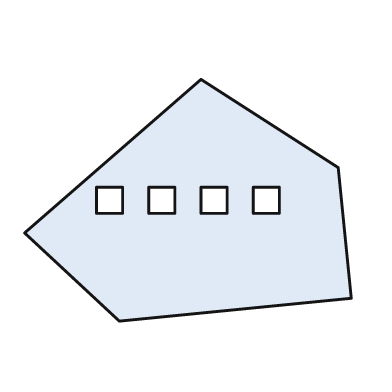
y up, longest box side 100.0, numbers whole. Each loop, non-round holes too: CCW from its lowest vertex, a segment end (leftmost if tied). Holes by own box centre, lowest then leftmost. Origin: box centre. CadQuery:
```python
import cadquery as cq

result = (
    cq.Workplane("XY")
    .moveTo(-21.0, -37.0)
    .lineTo(50.0, -30.0)
    .lineTo(46.0, 10.0)
    .lineTo(4.0, 37.0)
    .lineTo(-50.0, -10.0)
    .close()
    .moveTo(-28.0, -4.0)
    .lineTo(-20.0, -4.0)
    .lineTo(-20.0, 4.0)
    .lineTo(-28.0, 4.0)
    .close()
    .moveTo(-12.0, -4.0)
    .lineTo(-4.0, -4.0)
    .lineTo(-4.0, 4.0)
    .lineTo(-12.0, 4.0)
    .close()
    .moveTo(4.0, -4.0)
    .lineTo(12.0, -4.0)
    .lineTo(12.0, 4.0)
    .lineTo(4.0, 4.0)
    .close()
    .moveTo(20.0, -4.0)
    .lineTo(28.0, -4.0)
    .lineTo(28.0, 4.0)
    .lineTo(20.0, 4.0)
    .close()
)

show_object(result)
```